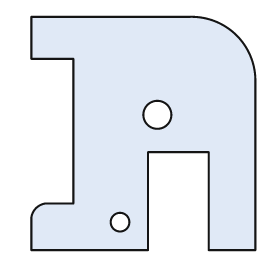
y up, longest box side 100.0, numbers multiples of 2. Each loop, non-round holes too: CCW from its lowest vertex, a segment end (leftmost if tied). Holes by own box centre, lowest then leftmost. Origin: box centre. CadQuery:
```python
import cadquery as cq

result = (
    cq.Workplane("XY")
    .moveTo(-48.0, -50.0)
    .lineTo(2.0, -50.0)
    .lineTo(2.0, -8.0)
    .lineTo(28.0, -8.0)
    .lineTo(28.0, -50.0)
    .lineTo(48.0, -50.0)
    .lineTo(48.0, 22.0)
    .threePointArc((40.0, 42.0), (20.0, 50.0))
    .lineTo(-48.0, 50.0)
    .lineTo(-48.0, 32.0)
    .lineTo(-30.0, 32.0)
    .lineTo(-30.0, -30.0)
    .lineTo(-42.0, -30.0)
    .threePointArc((-46.0, -32.0), (-48.0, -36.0))
    .close()
    .moveTo(-10.0, -38.0)
    .circle(4.0)
    .moveTo(6.0, 8.0)
    .circle(6.0)
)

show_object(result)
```